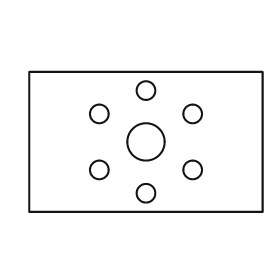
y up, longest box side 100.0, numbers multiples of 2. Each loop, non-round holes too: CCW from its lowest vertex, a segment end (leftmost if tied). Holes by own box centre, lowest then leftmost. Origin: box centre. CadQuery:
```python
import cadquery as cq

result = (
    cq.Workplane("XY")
    .moveTo(-50.0, -30.0)
    .lineTo(50.0, -30.0)
    .lineTo(50.0, 30.0)
    .lineTo(-50.0, 30.0)
    .close()
    .moveTo(0.0, -22.0)
    .circle(4.0)
    .moveTo(-20.0, -12.0)
    .circle(4.0)
    .moveTo(20.0, -12.0)
    .circle(4.0)
    .moveTo(0.0, 0.0)
    .circle(8.0)
    .moveTo(-20.0, 12.0)
    .circle(4.0)
    .moveTo(20.0, 12.0)
    .circle(4.0)
    .moveTo(0.0, 22.0)
    .circle(4.0)
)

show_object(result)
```